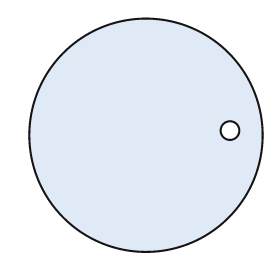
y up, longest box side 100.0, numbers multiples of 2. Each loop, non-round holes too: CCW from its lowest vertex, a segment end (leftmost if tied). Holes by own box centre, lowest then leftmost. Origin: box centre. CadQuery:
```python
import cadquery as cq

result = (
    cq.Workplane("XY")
    .moveTo(0.0, 0.0)
    .circle(50.0)
    .moveTo(36.0, 2.0)
    .circle(4.0)
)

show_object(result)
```